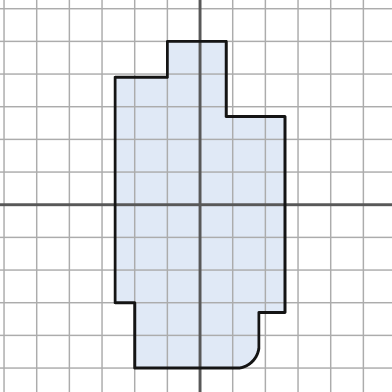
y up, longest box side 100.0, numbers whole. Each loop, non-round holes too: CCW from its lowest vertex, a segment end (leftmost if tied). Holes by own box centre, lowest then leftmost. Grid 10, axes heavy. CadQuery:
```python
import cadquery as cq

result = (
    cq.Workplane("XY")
    .moveTo(-20.0, -50.0)
    .lineTo(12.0, -50.0)
    .threePointArc((16.0, -48.0), (18.0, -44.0))
    .lineTo(18.0, -33.0)
    .lineTo(26.0, -33.0)
    .lineTo(26.0, 27.0)
    .lineTo(8.0, 27.0)
    .lineTo(8.0, 50.0)
    .lineTo(-10.0, 50.0)
    .lineTo(-10.0, 39.0)
    .lineTo(-26.0, 39.0)
    .lineTo(-26.0, -30.0)
    .lineTo(-20.0, -30.0)
    .close()
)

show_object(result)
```